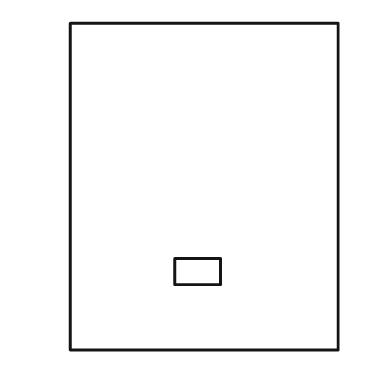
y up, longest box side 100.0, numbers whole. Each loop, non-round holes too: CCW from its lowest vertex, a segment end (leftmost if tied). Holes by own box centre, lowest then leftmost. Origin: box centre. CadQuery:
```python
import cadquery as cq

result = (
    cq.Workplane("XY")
    .moveTo(-41.0, -50.0)
    .lineTo(41.0, -50.0)
    .lineTo(41.0, 50.0)
    .lineTo(-41.0, 50.0)
    .close()
    .moveTo(-9.0, -30.0)
    .lineTo(5.0, -30.0)
    .lineTo(5.0, -22.0)
    .lineTo(-9.0, -22.0)
    .close()
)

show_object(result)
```